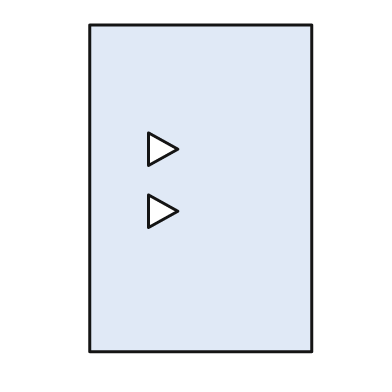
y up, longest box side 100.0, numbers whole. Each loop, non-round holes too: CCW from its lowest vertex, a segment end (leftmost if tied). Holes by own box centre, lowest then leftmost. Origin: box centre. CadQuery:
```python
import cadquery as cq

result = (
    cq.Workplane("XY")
    .moveTo(-34.0, -50.0)
    .lineTo(34.0, -50.0)
    .lineTo(34.0, 50.0)
    .lineTo(-34.0, 50.0)
    .close()
    .moveTo(-16.0, -12.0)
    .lineTo(-7.0, -7.0)
    .lineTo(-16.0, -2.0)
    .close()
    .moveTo(-16.0, 7.0)
    .lineTo(-7.0, 12.0)
    .lineTo(-16.0, 17.0)
    .close()
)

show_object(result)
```